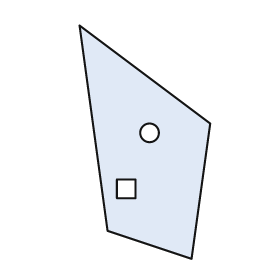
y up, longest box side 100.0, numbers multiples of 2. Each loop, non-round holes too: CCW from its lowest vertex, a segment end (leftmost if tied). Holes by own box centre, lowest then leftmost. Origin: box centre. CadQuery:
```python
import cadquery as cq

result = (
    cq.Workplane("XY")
    .moveTo(20.0, -50.0)
    .lineTo(28.0, 8.0)
    .lineTo(-28.0, 50.0)
    .lineTo(-16.0, -38.0)
    .close()
    .moveTo(-12.0, -24.0)
    .lineTo(-4.0, -24.0)
    .lineTo(-4.0, -16.0)
    .lineTo(-12.0, -16.0)
    .close()
    .moveTo(2.0, 4.0)
    .circle(4.0)
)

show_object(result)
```